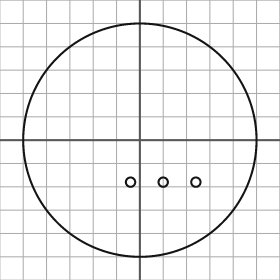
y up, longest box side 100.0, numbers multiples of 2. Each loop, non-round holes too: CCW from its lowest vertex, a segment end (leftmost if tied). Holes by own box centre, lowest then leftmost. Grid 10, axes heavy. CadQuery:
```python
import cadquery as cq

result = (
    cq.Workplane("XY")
    .moveTo(0.0, 0.0)
    .circle(50.0)
    .moveTo(-4.0, -18.0)
    .circle(2.0)
    .moveTo(10.0, -18.0)
    .circle(2.0)
    .moveTo(24.0, -18.0)
    .circle(2.0)
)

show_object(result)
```